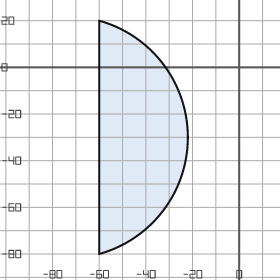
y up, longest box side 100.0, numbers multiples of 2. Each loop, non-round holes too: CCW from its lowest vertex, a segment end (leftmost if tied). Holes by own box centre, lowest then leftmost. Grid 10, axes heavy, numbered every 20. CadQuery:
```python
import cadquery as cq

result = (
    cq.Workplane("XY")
    .moveTo(-60.0, -80.0)
    .threePointArc((-22.0, -30.0), (-60.0, 20.0))
    .close()
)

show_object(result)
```